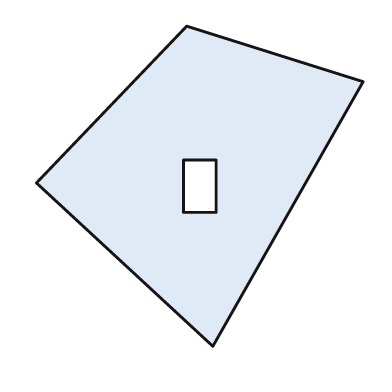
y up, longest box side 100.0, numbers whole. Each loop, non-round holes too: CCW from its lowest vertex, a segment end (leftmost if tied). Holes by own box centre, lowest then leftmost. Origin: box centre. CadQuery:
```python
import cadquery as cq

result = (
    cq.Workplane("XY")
    .moveTo(4.0, -49.0)
    .lineTo(50.0, 32.0)
    .lineTo(-4.0, 49.0)
    .lineTo(-50.0, 1.0)
    .close()
    .moveTo(-5.0, -8.0)
    .lineTo(5.0, -8.0)
    .lineTo(5.0, 8.0)
    .lineTo(-5.0, 8.0)
    .close()
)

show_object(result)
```